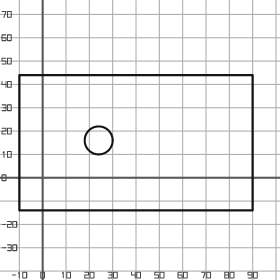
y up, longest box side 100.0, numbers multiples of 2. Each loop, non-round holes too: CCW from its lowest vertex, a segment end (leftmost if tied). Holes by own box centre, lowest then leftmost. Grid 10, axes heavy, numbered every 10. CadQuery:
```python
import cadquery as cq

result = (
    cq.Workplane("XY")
    .moveTo(-10.0, -14.0)
    .lineTo(90.0, -14.0)
    .lineTo(90.0, 44.0)
    .lineTo(-10.0, 44.0)
    .close()
    .moveTo(24.0, 16.0)
    .circle(6.0)
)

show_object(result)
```